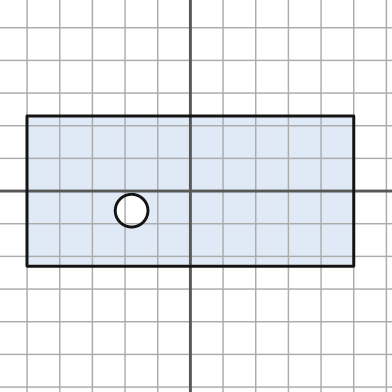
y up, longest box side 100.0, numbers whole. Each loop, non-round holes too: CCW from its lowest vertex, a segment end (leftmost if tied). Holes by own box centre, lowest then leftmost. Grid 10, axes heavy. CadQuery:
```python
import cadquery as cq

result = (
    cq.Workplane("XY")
    .moveTo(-50.0, -23.0)
    .lineTo(50.0, -23.0)
    .lineTo(50.0, 23.0)
    .lineTo(-50.0, 23.0)
    .close()
    .moveTo(-18.0, -6.0)
    .circle(5.0)
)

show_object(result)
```